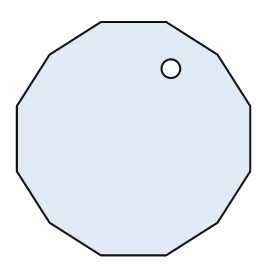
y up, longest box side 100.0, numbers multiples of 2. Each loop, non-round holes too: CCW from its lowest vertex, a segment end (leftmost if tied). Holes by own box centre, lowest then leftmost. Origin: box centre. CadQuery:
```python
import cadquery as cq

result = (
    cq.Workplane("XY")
    .moveTo(-14.0, -50.0)
    .lineTo(14.0, -50.0)
    .lineTo(36.0, -36.0)
    .lineTo(50.0, -14.0)
    .lineTo(50.0, 14.0)
    .lineTo(36.0, 36.0)
    .lineTo(14.0, 50.0)
    .lineTo(-14.0, 50.0)
    .lineTo(-36.0, 36.0)
    .lineTo(-50.0, 14.0)
    .lineTo(-50.0, -14.0)
    .lineTo(-36.0, -36.0)
    .close()
    .moveTo(16.0, 30.0)
    .circle(4.0)
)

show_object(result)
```